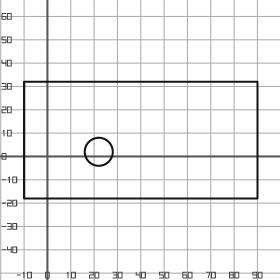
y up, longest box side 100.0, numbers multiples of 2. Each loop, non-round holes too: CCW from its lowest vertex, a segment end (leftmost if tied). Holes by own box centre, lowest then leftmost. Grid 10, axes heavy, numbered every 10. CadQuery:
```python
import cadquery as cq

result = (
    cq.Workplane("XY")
    .moveTo(-10.0, -18.0)
    .lineTo(90.0, -18.0)
    .lineTo(90.0, 32.0)
    .lineTo(-10.0, 32.0)
    .close()
    .moveTo(22.0, 2.0)
    .circle(6.0)
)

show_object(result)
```